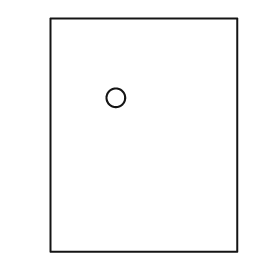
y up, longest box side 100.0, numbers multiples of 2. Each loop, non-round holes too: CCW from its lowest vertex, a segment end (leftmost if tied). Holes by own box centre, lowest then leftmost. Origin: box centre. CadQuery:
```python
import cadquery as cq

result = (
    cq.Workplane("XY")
    .moveTo(-40.0, -50.0)
    .lineTo(40.0, -50.0)
    .lineTo(40.0, 50.0)
    .lineTo(-40.0, 50.0)
    .close()
    .moveTo(-12.0, 16.0)
    .circle(4.0)
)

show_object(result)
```